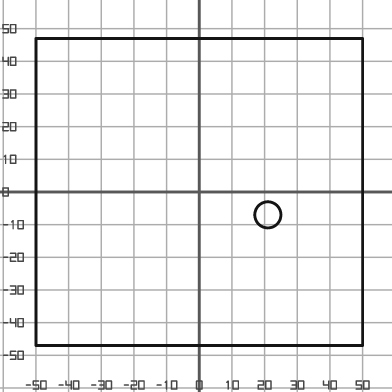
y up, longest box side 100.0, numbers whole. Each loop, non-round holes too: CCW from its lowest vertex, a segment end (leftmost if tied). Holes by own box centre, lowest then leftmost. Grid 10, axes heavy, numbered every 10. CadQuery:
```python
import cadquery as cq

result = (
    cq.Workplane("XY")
    .moveTo(-50.0, -47.0)
    .lineTo(50.0, -47.0)
    .lineTo(50.0, 47.0)
    .lineTo(-50.0, 47.0)
    .close()
    .moveTo(21.0, -7.0)
    .circle(4.0)
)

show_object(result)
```